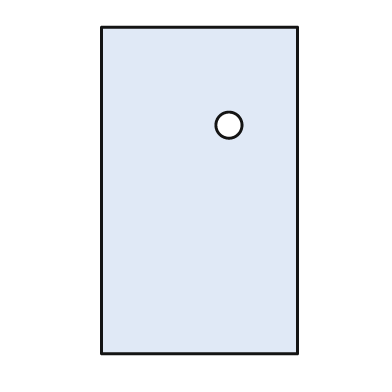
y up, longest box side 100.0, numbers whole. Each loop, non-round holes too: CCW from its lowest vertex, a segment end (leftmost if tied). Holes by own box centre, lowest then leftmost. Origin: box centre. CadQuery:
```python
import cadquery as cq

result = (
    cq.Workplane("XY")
    .moveTo(-30.0, -50.0)
    .lineTo(30.0, -50.0)
    .lineTo(30.0, 50.0)
    .lineTo(-30.0, 50.0)
    .close()
    .moveTo(9.0, 20.0)
    .circle(4.0)
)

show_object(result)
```